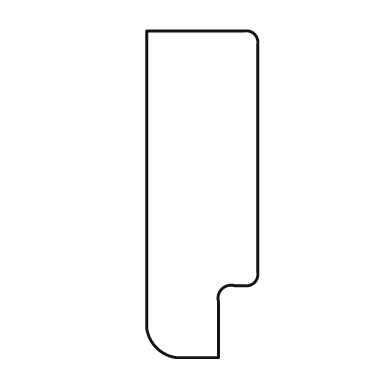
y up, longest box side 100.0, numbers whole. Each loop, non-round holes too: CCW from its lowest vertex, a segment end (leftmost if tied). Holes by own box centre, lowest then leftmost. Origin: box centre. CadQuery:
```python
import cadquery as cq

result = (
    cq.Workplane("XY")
    .moveTo(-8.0, -50.0)
    .lineTo(5.0, -50.0)
    .lineTo(5.0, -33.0)
    .threePointArc((6.0, -29.0), (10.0, -28.0))
    .lineTo(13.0, -28.0)
    .threePointArc((16.0, -27.0), (17.0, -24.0))
    .lineTo(17.0, 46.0)
    .threePointArc((16.0, 49.0), (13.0, 50.0))
    .lineTo(-17.0, 50.0)
    .lineTo(-17.0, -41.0)
    .threePointArc((-14.0, -47.0), (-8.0, -50.0))
    .close()
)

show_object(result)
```